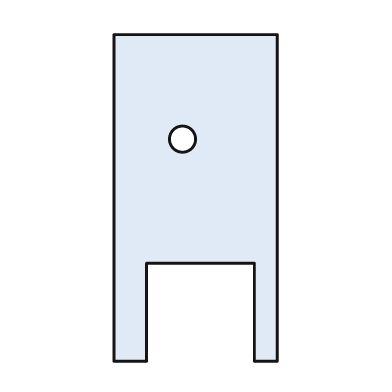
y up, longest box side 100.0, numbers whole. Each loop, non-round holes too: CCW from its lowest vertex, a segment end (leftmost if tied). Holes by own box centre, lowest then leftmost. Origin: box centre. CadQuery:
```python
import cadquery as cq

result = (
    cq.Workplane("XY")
    .moveTo(-25.0, -50.0)
    .lineTo(-15.0, -50.0)
    .lineTo(-15.0, -20.0)
    .lineTo(18.0, -20.0)
    .lineTo(18.0, -50.0)
    .lineTo(25.0, -50.0)
    .lineTo(25.0, 50.0)
    .lineTo(-25.0, 50.0)
    .close()
    .moveTo(-4.0, 18.0)
    .circle(4.0)
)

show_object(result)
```